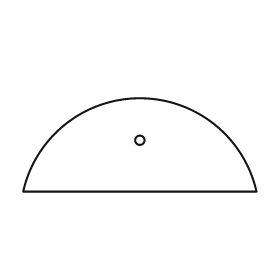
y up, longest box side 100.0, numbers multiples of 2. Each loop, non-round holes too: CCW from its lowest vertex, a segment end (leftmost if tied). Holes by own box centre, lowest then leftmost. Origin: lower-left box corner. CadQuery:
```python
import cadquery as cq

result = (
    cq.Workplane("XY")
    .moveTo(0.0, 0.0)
    .lineTo(100.0, 0.0)
    .threePointArc((50.0, 40.0), (0.0, 0.0))
    .close()
    .moveTo(50.0, 22.0)
    .circle(2.0)
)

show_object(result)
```